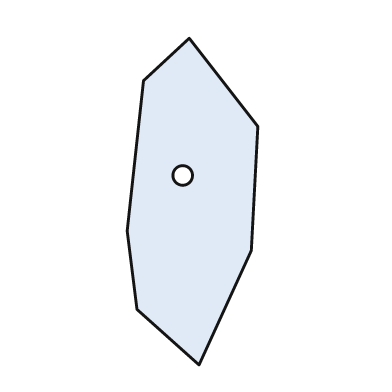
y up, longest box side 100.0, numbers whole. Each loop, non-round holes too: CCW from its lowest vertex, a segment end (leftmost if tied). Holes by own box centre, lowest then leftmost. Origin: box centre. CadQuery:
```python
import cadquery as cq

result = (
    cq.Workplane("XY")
    .moveTo(2.0, -50.0)
    .lineTo(18.0, -15.0)
    .lineTo(20.0, 23.0)
    .lineTo(-1.0, 50.0)
    .lineTo(-15.0, 37.0)
    .lineTo(-20.0, -9.0)
    .lineTo(-17.0, -33.0)
    .close()
    .moveTo(-3.0, 8.0)
    .circle(3.0)
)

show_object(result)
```